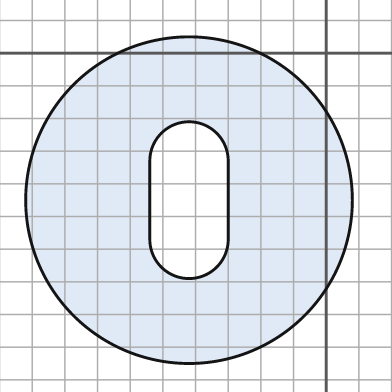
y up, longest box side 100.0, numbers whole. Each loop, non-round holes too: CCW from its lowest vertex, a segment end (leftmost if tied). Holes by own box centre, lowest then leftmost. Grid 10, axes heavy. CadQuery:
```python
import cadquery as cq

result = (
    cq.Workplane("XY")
    .moveTo(-42.0, -45.0)
    .circle(50.0)
    .moveTo(-54.0, -57.0)
    .threePointArc((-42.0, -69.0), (-30.0, -57.0))
    .lineTo(-30.0, -33.0)
    .threePointArc((-42.0, -21.0), (-54.0, -33.0))
    .close()
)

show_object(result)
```